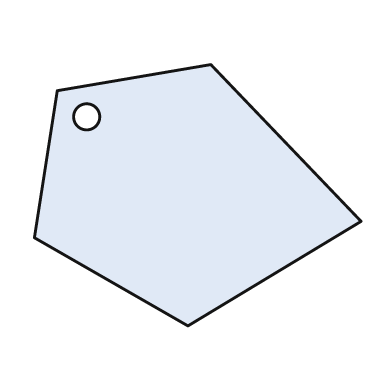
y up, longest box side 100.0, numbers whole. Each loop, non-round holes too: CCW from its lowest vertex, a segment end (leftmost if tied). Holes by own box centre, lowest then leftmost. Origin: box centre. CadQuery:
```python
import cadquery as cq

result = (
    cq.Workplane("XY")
    .moveTo(-3.0, -40.0)
    .lineTo(50.0, -8.0)
    .lineTo(4.0, 40.0)
    .lineTo(-43.0, 32.0)
    .lineTo(-50.0, -13.0)
    .close()
    .moveTo(-34.0, 24.0)
    .circle(4.0)
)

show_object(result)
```